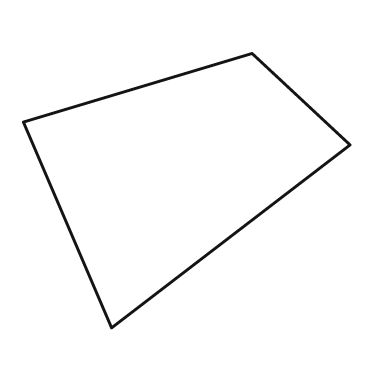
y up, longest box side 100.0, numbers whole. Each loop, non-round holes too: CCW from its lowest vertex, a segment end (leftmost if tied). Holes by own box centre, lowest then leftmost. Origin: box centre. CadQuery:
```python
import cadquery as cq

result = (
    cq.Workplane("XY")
    .moveTo(-23.0, -42.0)
    .lineTo(50.0, 14.0)
    .lineTo(20.0, 42.0)
    .lineTo(-50.0, 21.0)
    .close()
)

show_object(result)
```